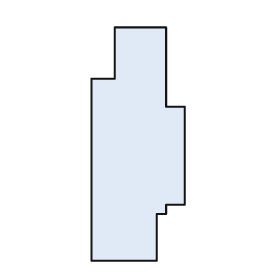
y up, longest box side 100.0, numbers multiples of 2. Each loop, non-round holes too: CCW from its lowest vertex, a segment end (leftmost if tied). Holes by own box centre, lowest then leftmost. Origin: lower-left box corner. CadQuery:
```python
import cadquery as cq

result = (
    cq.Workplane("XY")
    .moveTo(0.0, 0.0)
    .lineTo(28.0, 0.0)
    .lineTo(28.0, 20.0)
    .lineTo(32.0, 20.0)
    .lineTo(32.0, 24.0)
    .lineTo(40.0, 24.0)
    .lineTo(40.0, 66.0)
    .lineTo(32.0, 66.0)
    .lineTo(32.0, 100.0)
    .lineTo(10.0, 100.0)
    .lineTo(10.0, 78.0)
    .lineTo(0.0, 78.0)
    .close()
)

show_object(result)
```